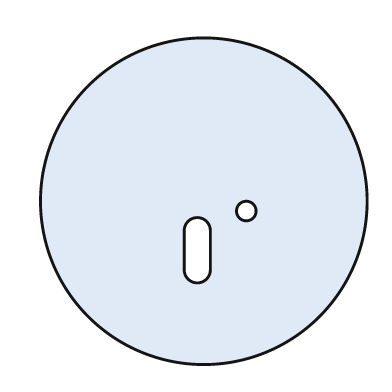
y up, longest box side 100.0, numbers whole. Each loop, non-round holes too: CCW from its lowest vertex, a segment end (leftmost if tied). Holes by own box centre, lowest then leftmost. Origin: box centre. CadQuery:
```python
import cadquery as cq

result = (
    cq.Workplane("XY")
    .moveTo(0.0, 0.0)
    .circle(50.0)
    .moveTo(-6.0, -21.0)
    .threePointArc((-2.0, -25.0), (2.0, -21.0))
    .lineTo(2.0, -9.0)
    .threePointArc((-2.0, -5.0), (-6.0, -9.0))
    .close()
    .moveTo(13.0, -3.0)
    .circle(3.0)
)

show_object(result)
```